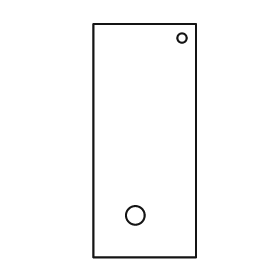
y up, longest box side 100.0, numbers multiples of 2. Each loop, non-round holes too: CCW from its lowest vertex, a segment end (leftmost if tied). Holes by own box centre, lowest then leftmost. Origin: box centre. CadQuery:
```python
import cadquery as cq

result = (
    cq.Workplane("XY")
    .moveTo(-22.0, -50.0)
    .lineTo(22.0, -50.0)
    .lineTo(22.0, 50.0)
    .lineTo(-22.0, 50.0)
    .close()
    .moveTo(-4.0, -32.0)
    .circle(4.0)
    .moveTo(16.0, 44.0)
    .circle(2.0)
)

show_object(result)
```